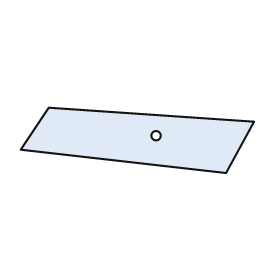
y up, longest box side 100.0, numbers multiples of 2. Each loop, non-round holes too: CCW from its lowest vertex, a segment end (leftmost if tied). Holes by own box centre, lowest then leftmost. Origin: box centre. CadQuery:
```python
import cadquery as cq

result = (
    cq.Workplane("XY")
    .moveTo(38.0, -14.0)
    .lineTo(50.0, 8.0)
    .lineTo(-38.0, 14.0)
    .lineTo(-50.0, -4.0)
    .close()
    .moveTo(8.0, 2.0)
    .circle(2.0)
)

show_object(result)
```